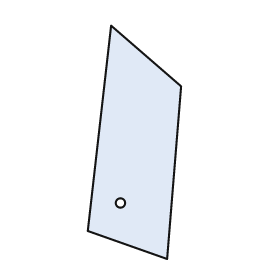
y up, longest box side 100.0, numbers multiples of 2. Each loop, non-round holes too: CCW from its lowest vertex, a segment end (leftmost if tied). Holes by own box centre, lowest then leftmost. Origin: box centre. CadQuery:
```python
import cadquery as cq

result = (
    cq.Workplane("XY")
    .moveTo(14.0, -50.0)
    .lineTo(20.0, 24.0)
    .lineTo(-10.0, 50.0)
    .lineTo(-20.0, -38.0)
    .close()
    .moveTo(-6.0, -26.0)
    .circle(2.0)
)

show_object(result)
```